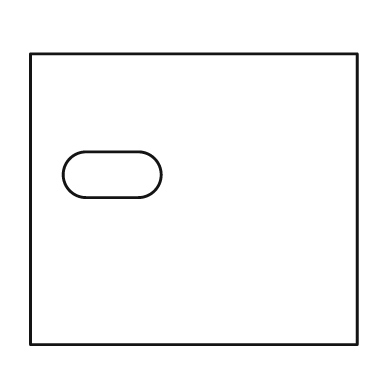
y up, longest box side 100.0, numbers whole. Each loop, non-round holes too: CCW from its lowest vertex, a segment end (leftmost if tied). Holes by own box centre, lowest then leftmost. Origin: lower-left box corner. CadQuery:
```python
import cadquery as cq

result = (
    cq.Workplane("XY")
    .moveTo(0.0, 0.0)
    .lineTo(100.0, 0.0)
    .lineTo(100.0, 89.0)
    .lineTo(0.0, 89.0)
    .close()
    .moveTo(17.0, 45.0)
    .lineTo(33.0, 45.0)
    .threePointArc((40.0, 52.0), (33.0, 59.0))
    .lineTo(17.0, 59.0)
    .threePointArc((10.0, 52.0), (17.0, 45.0))
    .close()
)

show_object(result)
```